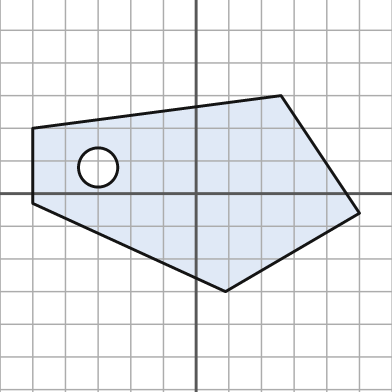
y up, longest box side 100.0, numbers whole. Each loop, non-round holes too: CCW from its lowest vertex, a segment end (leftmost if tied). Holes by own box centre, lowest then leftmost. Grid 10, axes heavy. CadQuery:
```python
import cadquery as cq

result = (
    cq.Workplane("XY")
    .moveTo(9.0, -30.0)
    .lineTo(50.0, -6.0)
    .lineTo(26.0, 30.0)
    .lineTo(-50.0, 20.0)
    .lineTo(-50.0, -3.0)
    .close()
    .moveTo(-30.0, 8.0)
    .circle(6.0)
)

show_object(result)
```